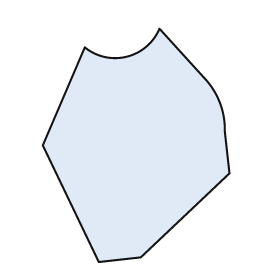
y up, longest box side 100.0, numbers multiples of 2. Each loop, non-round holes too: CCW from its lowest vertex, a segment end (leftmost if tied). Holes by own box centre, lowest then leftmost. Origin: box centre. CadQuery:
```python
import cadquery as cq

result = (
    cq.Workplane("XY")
    .moveTo(-16.0, -50.0)
    .lineTo(2.0, -48.0)
    .lineTo(40.0, -12.0)
    .lineTo(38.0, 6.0)
    .threePointArc((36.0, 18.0), (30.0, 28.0))
    .lineTo(10.0, 50.0)
    .threePointArc((-4.0, 38.0), (-22.0, 42.0))
    .lineTo(-40.0, 0.0)
    .close()
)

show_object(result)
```